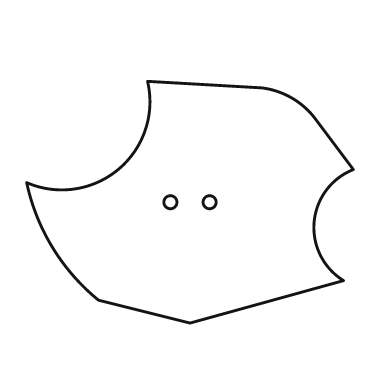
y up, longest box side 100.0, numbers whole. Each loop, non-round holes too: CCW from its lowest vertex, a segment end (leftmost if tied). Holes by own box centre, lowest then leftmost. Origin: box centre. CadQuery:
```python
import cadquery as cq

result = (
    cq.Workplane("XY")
    .moveTo(0.0, -37.0)
    .lineTo(47.0, -24.0)
    .threePointArc((38.0, -6.0), (50.0, 10.0))
    .lineTo(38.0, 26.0)
    .threePointArc((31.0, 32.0), (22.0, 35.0))
    .lineTo(-13.0, 37.0)
    .threePointArc((-22.0, 10.0), (-50.0, 6.0))
    .threePointArc((-42.0, -14.0), (-28.0, -30.0))
    .close()
    .moveTo(-6.0, 0.0)
    .circle(2.0)
    .moveTo(6.0, 0.0)
    .circle(2.0)
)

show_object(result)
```